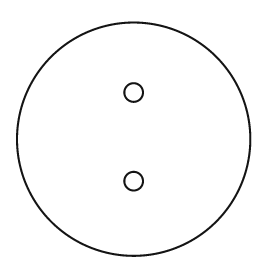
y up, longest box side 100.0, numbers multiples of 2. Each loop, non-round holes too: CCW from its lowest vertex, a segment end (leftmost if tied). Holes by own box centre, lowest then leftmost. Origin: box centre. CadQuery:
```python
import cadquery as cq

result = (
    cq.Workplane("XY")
    .moveTo(0.0, 0.0)
    .circle(50.0)
    .moveTo(0.0, -18.0)
    .circle(4.0)
    .moveTo(0.0, 20.0)
    .circle(4.0)
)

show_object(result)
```